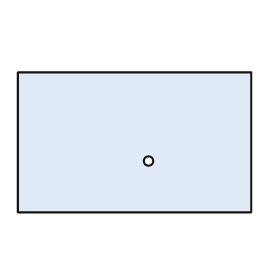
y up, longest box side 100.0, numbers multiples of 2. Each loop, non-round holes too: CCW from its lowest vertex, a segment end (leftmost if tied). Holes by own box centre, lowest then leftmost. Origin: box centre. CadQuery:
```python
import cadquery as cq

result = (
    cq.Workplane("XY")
    .moveTo(-50.0, -30.0)
    .lineTo(50.0, -30.0)
    .lineTo(50.0, 30.0)
    .lineTo(-50.0, 30.0)
    .close()
    .moveTo(6.0, -8.0)
    .circle(2.0)
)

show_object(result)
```